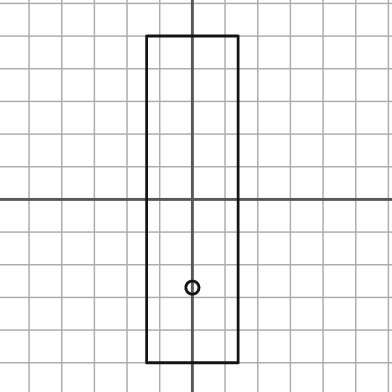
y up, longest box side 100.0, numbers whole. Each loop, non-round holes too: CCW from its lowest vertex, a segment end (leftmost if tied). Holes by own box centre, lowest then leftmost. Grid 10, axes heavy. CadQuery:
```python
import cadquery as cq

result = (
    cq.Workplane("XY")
    .moveTo(-14.0, -50.0)
    .lineTo(14.0, -50.0)
    .lineTo(14.0, 50.0)
    .lineTo(-14.0, 50.0)
    .close()
    .moveTo(0.0, -27.0)
    .circle(2.0)
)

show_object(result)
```